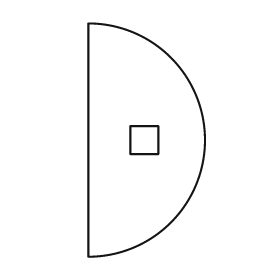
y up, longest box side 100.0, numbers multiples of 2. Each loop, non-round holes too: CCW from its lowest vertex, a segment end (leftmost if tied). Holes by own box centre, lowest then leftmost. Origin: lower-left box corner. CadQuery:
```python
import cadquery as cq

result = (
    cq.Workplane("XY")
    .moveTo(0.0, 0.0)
    .threePointArc((50.0, 50.0), (0.0, 100.0))
    .close()
    .moveTo(18.0, 44.0)
    .lineTo(30.0, 44.0)
    .lineTo(30.0, 56.0)
    .lineTo(18.0, 56.0)
    .close()
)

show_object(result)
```